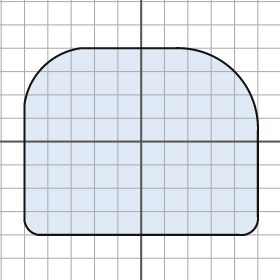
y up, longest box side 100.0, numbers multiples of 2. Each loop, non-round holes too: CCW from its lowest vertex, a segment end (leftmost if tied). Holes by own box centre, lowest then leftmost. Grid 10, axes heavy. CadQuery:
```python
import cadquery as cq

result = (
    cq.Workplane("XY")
    .moveTo(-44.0, -40.0)
    .lineTo(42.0, -40.0)
    .threePointArc((48.0, -38.0), (50.0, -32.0))
    .lineTo(50.0, 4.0)
    .threePointArc((40.0, 30.0), (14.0, 40.0))
    .lineTo(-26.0, 40.0)
    .threePointArc((-42.0, 32.0), (-50.0, 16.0))
    .lineTo(-50.0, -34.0)
    .threePointArc((-48.0, -38.0), (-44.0, -40.0))
    .close()
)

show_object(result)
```